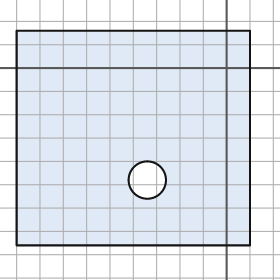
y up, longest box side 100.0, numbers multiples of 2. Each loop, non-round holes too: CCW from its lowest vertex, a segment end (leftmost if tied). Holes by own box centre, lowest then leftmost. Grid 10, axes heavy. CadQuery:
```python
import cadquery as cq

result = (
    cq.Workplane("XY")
    .moveTo(-90.0, -76.0)
    .lineTo(10.0, -76.0)
    .lineTo(10.0, 16.0)
    .lineTo(-90.0, 16.0)
    .close()
    .moveTo(-34.0, -48.0)
    .circle(8.0)
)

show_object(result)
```